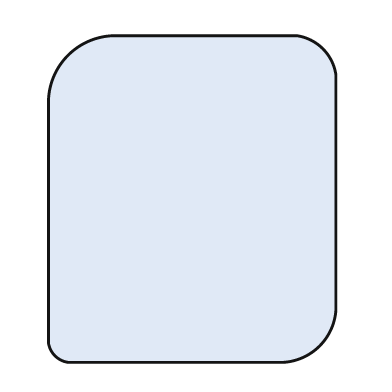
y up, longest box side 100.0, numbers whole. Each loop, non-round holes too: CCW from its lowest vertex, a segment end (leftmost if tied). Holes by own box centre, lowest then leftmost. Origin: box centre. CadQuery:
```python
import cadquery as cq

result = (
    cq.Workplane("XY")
    .moveTo(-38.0, -50.0)
    .lineTo(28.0, -50.0)
    .threePointArc((39.0, -45.0), (44.0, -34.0))
    .lineTo(44.0, 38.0)
    .threePointArc((40.0, 46.0), (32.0, 50.0))
    .lineTo(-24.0, 50.0)
    .threePointArc((-38.0, 44.0), (-44.0, 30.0))
    .lineTo(-44.0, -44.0)
    .threePointArc((-42.0, -48.0), (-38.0, -50.0))
    .close()
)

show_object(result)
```